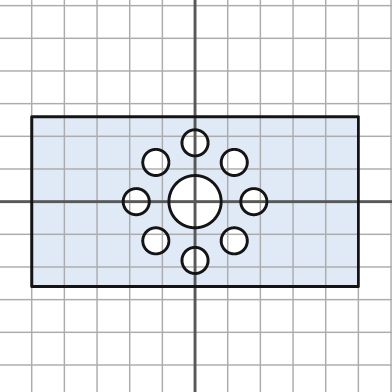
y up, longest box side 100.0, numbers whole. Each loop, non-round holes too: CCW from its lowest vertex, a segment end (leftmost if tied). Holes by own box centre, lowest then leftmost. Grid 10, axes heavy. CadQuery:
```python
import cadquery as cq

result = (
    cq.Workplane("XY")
    .moveTo(-50.0, -26.0)
    .lineTo(50.0, -26.0)
    .lineTo(50.0, 26.0)
    .lineTo(-50.0, 26.0)
    .close()
    .moveTo(0.0, -18.0)
    .circle(4.0)
    .moveTo(-12.0, -12.0)
    .circle(4.0)
    .moveTo(12.0, -12.0)
    .circle(4.0)
    .moveTo(-18.0, 0.0)
    .circle(4.0)
    .moveTo(0.0, 0.0)
    .circle(8.0)
    .moveTo(18.0, 0.0)
    .circle(4.0)
    .moveTo(-12.0, 12.0)
    .circle(4.0)
    .moveTo(12.0, 12.0)
    .circle(4.0)
    .moveTo(0.0, 18.0)
    .circle(4.0)
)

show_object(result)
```